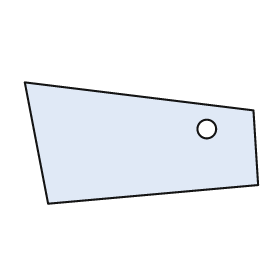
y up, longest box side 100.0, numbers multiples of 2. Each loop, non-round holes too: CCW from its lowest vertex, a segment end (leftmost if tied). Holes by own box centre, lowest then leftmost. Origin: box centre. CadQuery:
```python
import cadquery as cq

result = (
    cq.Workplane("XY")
    .moveTo(-40.0, -26.0)
    .lineTo(50.0, -18.0)
    .lineTo(48.0, 14.0)
    .lineTo(-50.0, 26.0)
    .close()
    .moveTo(28.0, 6.0)
    .circle(4.0)
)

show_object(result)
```